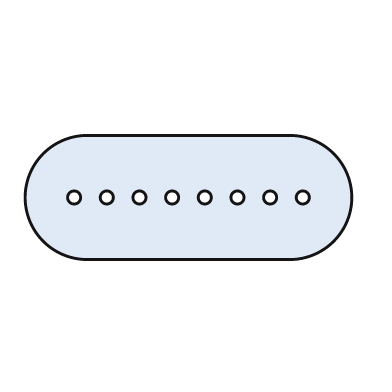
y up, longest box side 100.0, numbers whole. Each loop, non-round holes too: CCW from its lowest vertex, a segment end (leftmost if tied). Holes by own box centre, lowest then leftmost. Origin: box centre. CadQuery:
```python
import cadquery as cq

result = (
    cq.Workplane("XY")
    .moveTo(-31.0, -19.0)
    .lineTo(31.0, -19.0)
    .threePointArc((50.0, 0.0), (31.0, 19.0))
    .lineTo(-31.0, 19.0)
    .threePointArc((-50.0, 0.0), (-31.0, -19.0))
    .close()
    .moveTo(-35.0, 0.0)
    .circle(2.0)
    .moveTo(-25.0, 0.0)
    .circle(2.0)
    .moveTo(-15.0, 0.0)
    .circle(2.0)
    .moveTo(-5.0, 0.0)
    .circle(2.0)
    .moveTo(5.0, 0.0)
    .circle(2.0)
    .moveTo(15.0, 0.0)
    .circle(2.0)
    .moveTo(25.0, 0.0)
    .circle(2.0)
    .moveTo(35.0, 0.0)
    .circle(2.0)
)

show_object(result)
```